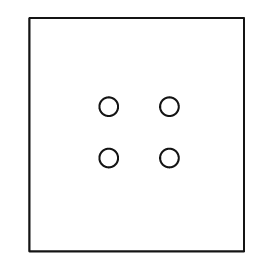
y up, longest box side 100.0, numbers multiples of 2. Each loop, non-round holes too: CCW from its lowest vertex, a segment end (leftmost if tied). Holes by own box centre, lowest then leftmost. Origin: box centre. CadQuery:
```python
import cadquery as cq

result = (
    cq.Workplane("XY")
    .moveTo(-46.0, -50.0)
    .lineTo(46.0, -50.0)
    .lineTo(46.0, 50.0)
    .lineTo(-46.0, 50.0)
    .close()
    .moveTo(-12.0, -10.0)
    .circle(4.0)
    .moveTo(14.0, -10.0)
    .circle(4.0)
    .moveTo(-12.0, 12.0)
    .circle(4.0)
    .moveTo(14.0, 12.0)
    .circle(4.0)
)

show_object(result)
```